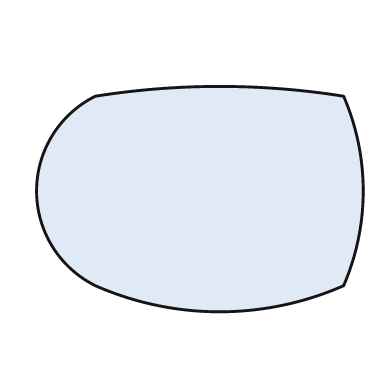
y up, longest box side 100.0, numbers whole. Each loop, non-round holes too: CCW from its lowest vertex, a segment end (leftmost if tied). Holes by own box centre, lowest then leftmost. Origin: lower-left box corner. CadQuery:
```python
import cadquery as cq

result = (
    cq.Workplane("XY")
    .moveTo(18.0, 8.0)
    .threePointArc((56.0, 0.0), (94.0, 8.0))
    .threePointArc((100.0, 37.0), (94.0, 66.0))
    .threePointArc((56.0, 69.0), (18.0, 66.0))
    .threePointArc((0.0, 37.0), (18.0, 8.0))
    .close()
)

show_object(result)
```